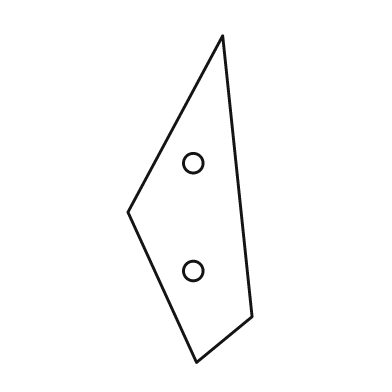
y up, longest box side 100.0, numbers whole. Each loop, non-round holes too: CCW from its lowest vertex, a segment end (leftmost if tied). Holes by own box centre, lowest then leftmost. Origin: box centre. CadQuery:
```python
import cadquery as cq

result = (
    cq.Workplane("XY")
    .moveTo(2.0, -50.0)
    .lineTo(19.0, -36.0)
    .lineTo(10.0, 50.0)
    .lineTo(-19.0, -4.0)
    .close()
    .moveTo(1.0, -22.0)
    .circle(3.0)
    .moveTo(1.0, 11.0)
    .circle(3.0)
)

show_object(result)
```